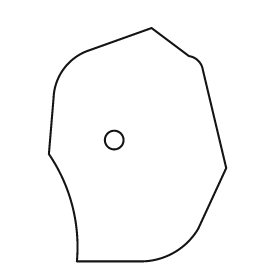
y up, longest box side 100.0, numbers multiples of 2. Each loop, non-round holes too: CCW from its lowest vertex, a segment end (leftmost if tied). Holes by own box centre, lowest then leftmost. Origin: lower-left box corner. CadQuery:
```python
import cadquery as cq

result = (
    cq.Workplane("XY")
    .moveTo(12.0, 0.0)
    .lineTo(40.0, 0.0)
    .threePointArc((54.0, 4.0), (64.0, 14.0))
    .lineTo(76.0, 40.0)
    .lineTo(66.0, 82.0)
    .threePointArc((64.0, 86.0), (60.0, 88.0))
    .lineTo(44.0, 100.0)
    .lineTo(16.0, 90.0)
    .threePointArc((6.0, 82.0), (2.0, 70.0))
    .lineTo(0.0, 46.0)
    .threePointArc((10.0, 24.0), (12.0, 0.0))
    .close()
    .moveTo(28.0, 52.0)
    .circle(4.0)
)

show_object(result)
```